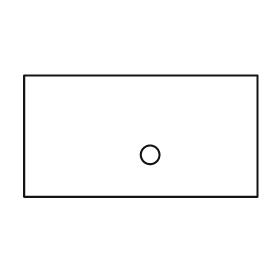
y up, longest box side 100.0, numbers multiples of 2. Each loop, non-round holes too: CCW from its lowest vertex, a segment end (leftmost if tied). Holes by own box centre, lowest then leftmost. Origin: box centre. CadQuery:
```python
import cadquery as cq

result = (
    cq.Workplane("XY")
    .moveTo(-50.0, -26.0)
    .lineTo(50.0, -26.0)
    .lineTo(50.0, 26.0)
    .lineTo(-50.0, 26.0)
    .close()
    .moveTo(4.0, -8.0)
    .circle(4.0)
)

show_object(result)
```